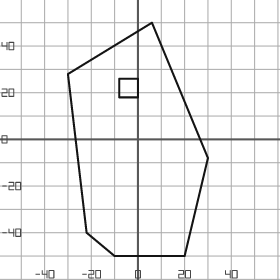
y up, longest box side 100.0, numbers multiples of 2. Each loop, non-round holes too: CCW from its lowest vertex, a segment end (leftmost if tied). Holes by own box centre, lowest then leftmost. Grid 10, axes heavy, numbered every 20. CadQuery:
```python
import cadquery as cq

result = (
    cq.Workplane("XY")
    .moveTo(-10.0, -50.0)
    .lineTo(20.0, -50.0)
    .lineTo(30.0, -8.0)
    .lineTo(6.0, 50.0)
    .lineTo(-30.0, 28.0)
    .lineTo(-22.0, -40.0)
    .close()
    .moveTo(-8.0, 18.0)
    .lineTo(0.0, 18.0)
    .lineTo(0.0, 26.0)
    .lineTo(-8.0, 26.0)
    .close()
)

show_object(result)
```